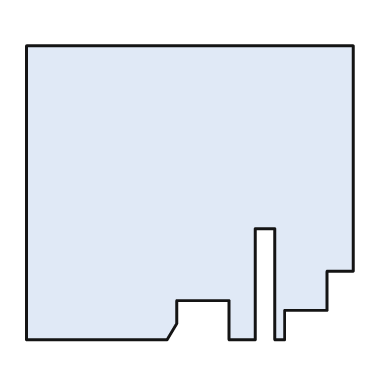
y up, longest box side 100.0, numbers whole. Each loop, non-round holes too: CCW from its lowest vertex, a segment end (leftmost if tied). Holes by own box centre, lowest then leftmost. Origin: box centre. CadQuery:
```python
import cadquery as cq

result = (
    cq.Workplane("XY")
    .moveTo(-50.0, -45.0)
    .lineTo(-7.0, -45.0)
    .lineTo(-4.0, -40.0)
    .lineTo(-4.0, -33.0)
    .lineTo(12.0, -33.0)
    .lineTo(12.0, -45.0)
    .lineTo(20.0, -45.0)
    .lineTo(20.0, -11.0)
    .lineTo(26.0, -11.0)
    .lineTo(26.0, -45.0)
    .lineTo(29.0, -45.0)
    .lineTo(29.0, -36.0)
    .lineTo(42.0, -36.0)
    .lineTo(42.0, -24.0)
    .lineTo(50.0, -24.0)
    .lineTo(50.0, 45.0)
    .lineTo(-50.0, 45.0)
    .close()
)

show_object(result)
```